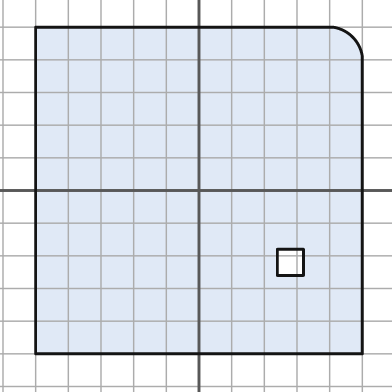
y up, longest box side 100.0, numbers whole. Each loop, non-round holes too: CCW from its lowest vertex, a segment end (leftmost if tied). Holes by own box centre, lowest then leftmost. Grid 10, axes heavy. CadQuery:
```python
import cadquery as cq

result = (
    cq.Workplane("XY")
    .moveTo(-50.0, -50.0)
    .lineTo(50.0, -50.0)
    .lineTo(50.0, 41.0)
    .threePointArc((47.0, 47.0), (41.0, 50.0))
    .lineTo(-50.0, 50.0)
    .close()
    .moveTo(24.0, -26.0)
    .lineTo(32.0, -26.0)
    .lineTo(32.0, -18.0)
    .lineTo(24.0, -18.0)
    .close()
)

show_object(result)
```